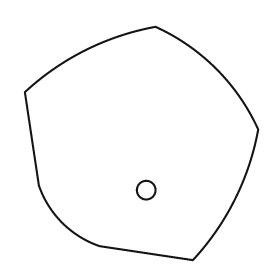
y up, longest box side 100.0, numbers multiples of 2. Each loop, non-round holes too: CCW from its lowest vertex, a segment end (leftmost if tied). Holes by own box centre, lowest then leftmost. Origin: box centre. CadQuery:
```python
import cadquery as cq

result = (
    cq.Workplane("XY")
    .moveTo(22.0, -50.0)
    .threePointArc((40.0, -24.0), (50.0, 6.0))
    .threePointArc((32.0, 32.0), (6.0, 50.0))
    .threePointArc((-24.0, 40.0), (-50.0, 22.0))
    .lineTo(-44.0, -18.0)
    .threePointArc((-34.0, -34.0), (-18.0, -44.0))
    .close()
    .moveTo(2.0, -20.0)
    .circle(4.0)
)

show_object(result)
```